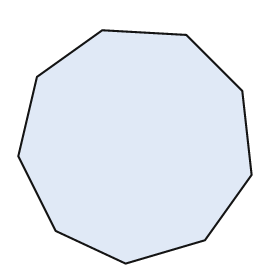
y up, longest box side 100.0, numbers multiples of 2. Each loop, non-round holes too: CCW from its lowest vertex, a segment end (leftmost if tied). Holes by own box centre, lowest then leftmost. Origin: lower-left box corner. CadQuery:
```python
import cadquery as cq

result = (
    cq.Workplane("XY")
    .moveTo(46.0, 0.0)
    .lineTo(80.0, 10.0)
    .lineTo(100.0, 38.0)
    .lineTo(96.0, 74.0)
    .lineTo(72.0, 98.0)
    .lineTo(36.0, 100.0)
    .lineTo(8.0, 80.0)
    .lineTo(0.0, 46.0)
    .lineTo(16.0, 14.0)
    .close()
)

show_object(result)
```